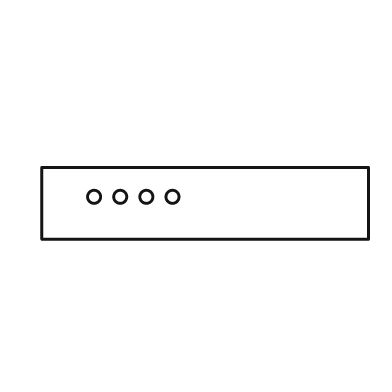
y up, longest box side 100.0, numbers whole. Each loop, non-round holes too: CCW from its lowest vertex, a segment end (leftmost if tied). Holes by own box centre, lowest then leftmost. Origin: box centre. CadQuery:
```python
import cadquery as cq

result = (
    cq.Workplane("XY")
    .moveTo(-50.0, -11.0)
    .lineTo(50.0, -11.0)
    .lineTo(50.0, 11.0)
    .lineTo(-50.0, 11.0)
    .close()
    .moveTo(-34.0, 2.0)
    .circle(2.0)
    .moveTo(-26.0, 2.0)
    .circle(2.0)
    .moveTo(-18.0, 2.0)
    .circle(2.0)
    .moveTo(-10.0, 2.0)
    .circle(2.0)
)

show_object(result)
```